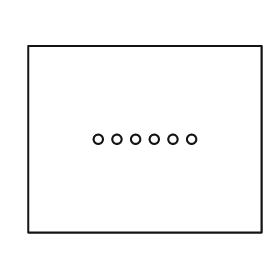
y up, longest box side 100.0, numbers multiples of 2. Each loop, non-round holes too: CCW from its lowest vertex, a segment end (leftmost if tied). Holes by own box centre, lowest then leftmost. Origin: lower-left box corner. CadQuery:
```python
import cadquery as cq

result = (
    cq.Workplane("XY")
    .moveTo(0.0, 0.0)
    .lineTo(100.0, 0.0)
    .lineTo(100.0, 80.0)
    .lineTo(0.0, 80.0)
    .close()
    .moveTo(30.0, 40.0)
    .circle(2.0)
    .moveTo(38.0, 40.0)
    .circle(2.0)
    .moveTo(46.0, 40.0)
    .circle(2.0)
    .moveTo(54.0, 40.0)
    .circle(2.0)
    .moveTo(62.0, 40.0)
    .circle(2.0)
    .moveTo(70.0, 40.0)
    .circle(2.0)
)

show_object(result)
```